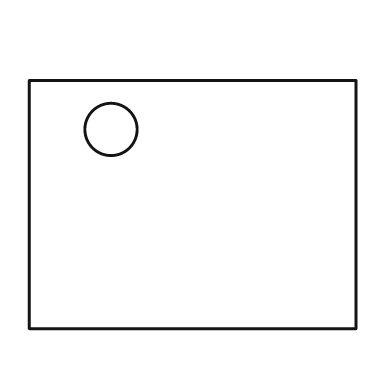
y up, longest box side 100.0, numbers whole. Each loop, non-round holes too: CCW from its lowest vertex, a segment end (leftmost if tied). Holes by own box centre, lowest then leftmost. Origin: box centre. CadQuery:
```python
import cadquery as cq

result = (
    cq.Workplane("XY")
    .moveTo(-50.0, -38.0)
    .lineTo(50.0, -38.0)
    .lineTo(50.0, 38.0)
    .lineTo(-50.0, 38.0)
    .close()
    .moveTo(-25.0, 23.0)
    .circle(8.0)
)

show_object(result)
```